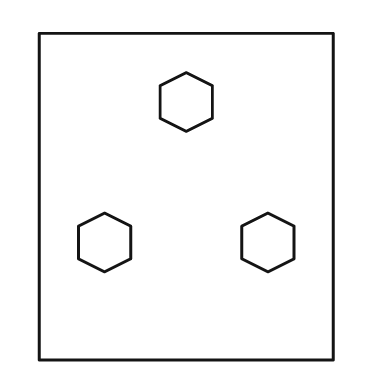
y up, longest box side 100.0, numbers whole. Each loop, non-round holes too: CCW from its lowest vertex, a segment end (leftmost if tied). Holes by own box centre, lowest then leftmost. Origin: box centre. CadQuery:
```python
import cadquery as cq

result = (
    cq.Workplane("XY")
    .moveTo(-45.0, -50.0)
    .lineTo(45.0, -50.0)
    .lineTo(45.0, 50.0)
    .lineTo(-45.0, 50.0)
    .close()
    .moveTo(-25.0, -23.0)
    .lineTo(-17.0, -19.0)
    .lineTo(-17.0, -9.0)
    .lineTo(-25.0, -5.0)
    .lineTo(-33.0, -9.0)
    .lineTo(-33.0, -19.0)
    .close()
    .moveTo(25.0, -23.0)
    .lineTo(33.0, -19.0)
    .lineTo(33.0, -9.0)
    .lineTo(25.0, -5.0)
    .lineTo(17.0, -9.0)
    .lineTo(17.0, -19.0)
    .close()
    .moveTo(0.0, 20.0)
    .lineTo(8.0, 24.0)
    .lineTo(8.0, 34.0)
    .lineTo(0.0, 38.0)
    .lineTo(-8.0, 34.0)
    .lineTo(-8.0, 24.0)
    .close()
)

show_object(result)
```